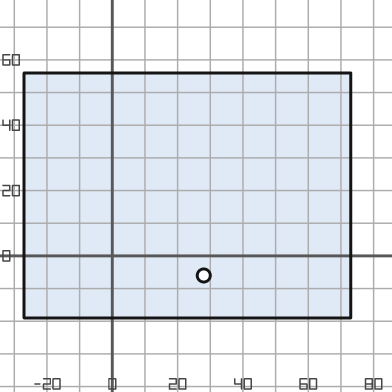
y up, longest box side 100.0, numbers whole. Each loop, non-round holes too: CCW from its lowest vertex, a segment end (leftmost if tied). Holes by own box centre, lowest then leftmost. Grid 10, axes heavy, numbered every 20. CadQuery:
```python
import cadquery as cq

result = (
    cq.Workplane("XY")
    .moveTo(-27.0, -19.0)
    .lineTo(73.0, -19.0)
    .lineTo(73.0, 56.0)
    .lineTo(-27.0, 56.0)
    .close()
    .moveTo(28.0, -6.0)
    .circle(2.0)
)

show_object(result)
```